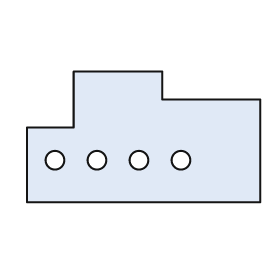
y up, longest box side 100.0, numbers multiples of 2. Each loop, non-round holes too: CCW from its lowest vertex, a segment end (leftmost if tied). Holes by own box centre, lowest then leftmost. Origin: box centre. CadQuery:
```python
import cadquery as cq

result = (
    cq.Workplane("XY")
    .moveTo(-50.0, -28.0)
    .lineTo(50.0, -28.0)
    .lineTo(50.0, 16.0)
    .lineTo(8.0, 16.0)
    .lineTo(8.0, 28.0)
    .lineTo(-30.0, 28.0)
    .lineTo(-30.0, 4.0)
    .lineTo(-50.0, 4.0)
    .close()
    .moveTo(-38.0, -10.0)
    .circle(4.0)
    .moveTo(-20.0, -10.0)
    .circle(4.0)
    .moveTo(-2.0, -10.0)
    .circle(4.0)
    .moveTo(16.0, -10.0)
    .circle(4.0)
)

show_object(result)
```